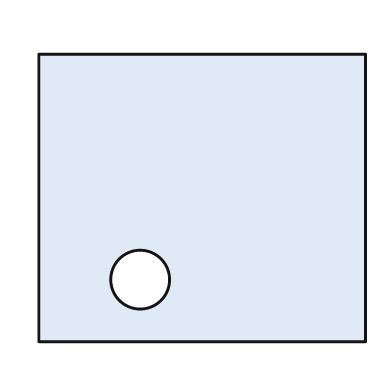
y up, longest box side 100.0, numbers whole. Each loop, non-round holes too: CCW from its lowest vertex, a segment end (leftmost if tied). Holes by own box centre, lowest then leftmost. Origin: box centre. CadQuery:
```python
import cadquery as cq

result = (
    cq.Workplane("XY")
    .moveTo(-50.0, -44.0)
    .lineTo(50.0, -44.0)
    .lineTo(50.0, 44.0)
    .lineTo(-50.0, 44.0)
    .close()
    .moveTo(-19.0, -25.0)
    .circle(9.0)
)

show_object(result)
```